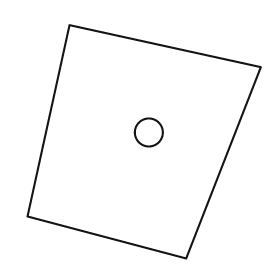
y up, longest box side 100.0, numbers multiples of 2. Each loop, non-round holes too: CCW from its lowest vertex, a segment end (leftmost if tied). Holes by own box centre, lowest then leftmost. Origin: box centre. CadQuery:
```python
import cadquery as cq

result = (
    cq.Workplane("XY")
    .moveTo(18.0, -50.0)
    .lineTo(50.0, 32.0)
    .lineTo(-32.0, 50.0)
    .lineTo(-50.0, -32.0)
    .close()
    .moveTo(2.0, 4.0)
    .circle(6.0)
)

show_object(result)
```